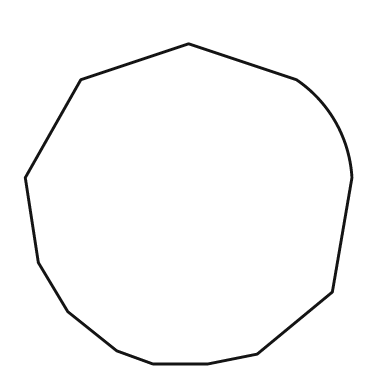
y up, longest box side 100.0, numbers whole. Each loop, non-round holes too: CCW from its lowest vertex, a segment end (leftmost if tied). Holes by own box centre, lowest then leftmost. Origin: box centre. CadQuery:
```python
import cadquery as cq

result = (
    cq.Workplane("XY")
    .moveTo(-11.0, -49.0)
    .lineTo(6.0, -49.0)
    .lineTo(21.0, -46.0)
    .lineTo(44.0, -27.0)
    .lineTo(50.0, 8.0)
    .threePointArc((45.0, 25.0), (33.0, 38.0))
    .lineTo(0.0, 49.0)
    .lineTo(-33.0, 38.0)
    .lineTo(-50.0, 8.0)
    .lineTo(-46.0, -18.0)
    .lineTo(-37.0, -33.0)
    .lineTo(-22.0, -45.0)
    .close()
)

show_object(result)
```